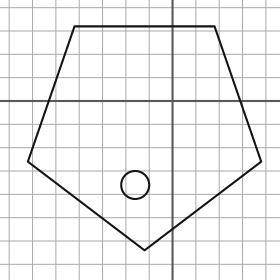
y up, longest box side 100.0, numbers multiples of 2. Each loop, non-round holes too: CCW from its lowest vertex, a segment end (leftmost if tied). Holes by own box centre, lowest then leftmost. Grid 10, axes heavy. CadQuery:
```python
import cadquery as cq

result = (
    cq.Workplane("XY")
    .moveTo(-12.0, -64.0)
    .lineTo(38.0, -26.0)
    .lineTo(18.0, 32.0)
    .lineTo(-42.0, 32.0)
    .lineTo(-62.0, -26.0)
    .close()
    .moveTo(-16.0, -36.0)
    .circle(6.0)
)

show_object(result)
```